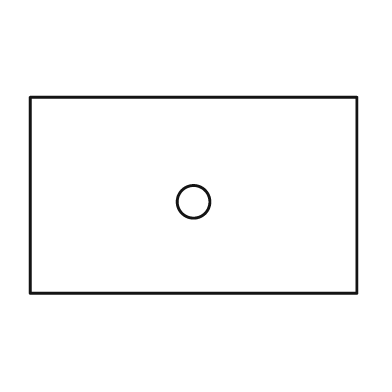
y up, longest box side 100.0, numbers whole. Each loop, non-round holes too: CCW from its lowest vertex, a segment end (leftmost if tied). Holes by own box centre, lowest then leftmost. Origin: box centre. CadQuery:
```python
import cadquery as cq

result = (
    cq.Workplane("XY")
    .moveTo(-50.0, -30.0)
    .lineTo(50.0, -30.0)
    .lineTo(50.0, 30.0)
    .lineTo(-50.0, 30.0)
    .close()
    .moveTo(0.0, -2.0)
    .circle(5.0)
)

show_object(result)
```